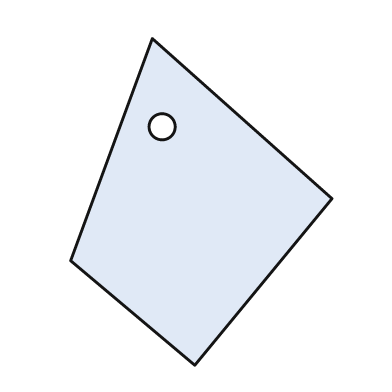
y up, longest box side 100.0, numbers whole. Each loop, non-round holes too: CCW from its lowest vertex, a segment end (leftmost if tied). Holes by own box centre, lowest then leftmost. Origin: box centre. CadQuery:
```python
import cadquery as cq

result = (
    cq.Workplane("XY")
    .moveTo(-2.0, -50.0)
    .lineTo(40.0, 1.0)
    .lineTo(-15.0, 50.0)
    .lineTo(-40.0, -18.0)
    .close()
    .moveTo(-12.0, 23.0)
    .circle(4.0)
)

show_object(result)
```